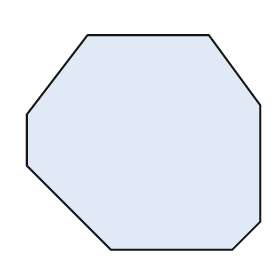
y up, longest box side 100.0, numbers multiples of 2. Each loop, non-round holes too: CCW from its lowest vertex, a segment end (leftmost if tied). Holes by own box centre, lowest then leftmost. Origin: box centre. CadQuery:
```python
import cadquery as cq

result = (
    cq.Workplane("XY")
    .moveTo(-14.0, -46.0)
    .lineTo(38.0, -46.0)
    .lineTo(50.0, -34.0)
    .lineTo(50.0, 16.0)
    .lineTo(28.0, 46.0)
    .lineTo(-24.0, 46.0)
    .lineTo(-50.0, 12.0)
    .lineTo(-50.0, -10.0)
    .close()
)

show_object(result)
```